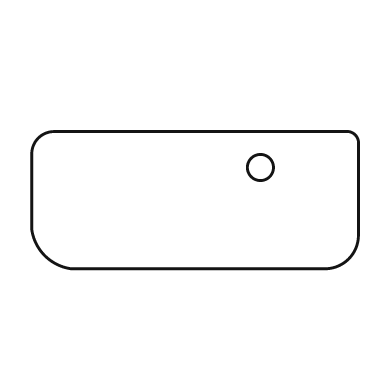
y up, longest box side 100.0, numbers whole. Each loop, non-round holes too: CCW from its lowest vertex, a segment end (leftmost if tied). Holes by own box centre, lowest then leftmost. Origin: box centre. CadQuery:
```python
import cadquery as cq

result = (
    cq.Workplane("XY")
    .moveTo(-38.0, -21.0)
    .lineTo(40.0, -21.0)
    .threePointArc((47.0, -18.0), (50.0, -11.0))
    .lineTo(50.0, 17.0)
    .threePointArc((49.0, 20.0), (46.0, 21.0))
    .lineTo(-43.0, 21.0)
    .threePointArc((-48.0, 19.0), (-50.0, 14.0))
    .lineTo(-50.0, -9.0)
    .threePointArc((-46.0, -17.0), (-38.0, -21.0))
    .close()
    .moveTo(20.0, 10.0)
    .circle(4.0)
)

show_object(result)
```